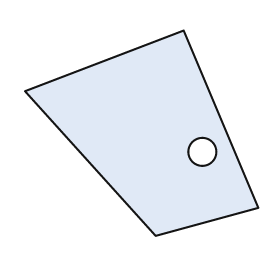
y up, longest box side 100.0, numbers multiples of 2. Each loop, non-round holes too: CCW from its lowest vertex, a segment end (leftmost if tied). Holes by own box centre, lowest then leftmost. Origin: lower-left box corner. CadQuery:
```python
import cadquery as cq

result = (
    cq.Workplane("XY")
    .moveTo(56.0, 0.0)
    .lineTo(100.0, 12.0)
    .lineTo(68.0, 88.0)
    .lineTo(0.0, 62.0)
    .close()
    .moveTo(76.0, 36.0)
    .circle(6.0)
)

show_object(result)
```